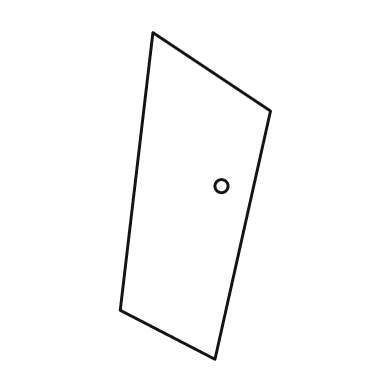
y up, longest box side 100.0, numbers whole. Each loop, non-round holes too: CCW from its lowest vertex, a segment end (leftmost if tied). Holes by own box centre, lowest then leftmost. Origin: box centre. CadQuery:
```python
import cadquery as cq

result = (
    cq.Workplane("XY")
    .moveTo(6.0, -50.0)
    .lineTo(23.0, 26.0)
    .lineTo(-13.0, 50.0)
    .lineTo(-23.0, -35.0)
    .close()
    .moveTo(8.0, 3.0)
    .circle(2.0)
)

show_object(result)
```